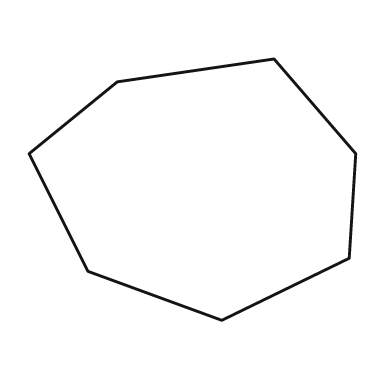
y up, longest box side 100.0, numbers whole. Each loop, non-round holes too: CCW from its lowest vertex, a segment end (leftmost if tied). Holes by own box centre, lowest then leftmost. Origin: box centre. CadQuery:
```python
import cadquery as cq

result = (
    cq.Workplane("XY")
    .moveTo(9.0, -40.0)
    .lineTo(48.0, -21.0)
    .lineTo(50.0, 11.0)
    .lineTo(25.0, 40.0)
    .lineTo(-23.0, 33.0)
    .lineTo(-50.0, 11.0)
    .lineTo(-32.0, -25.0)
    .close()
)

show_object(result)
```